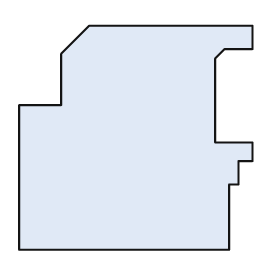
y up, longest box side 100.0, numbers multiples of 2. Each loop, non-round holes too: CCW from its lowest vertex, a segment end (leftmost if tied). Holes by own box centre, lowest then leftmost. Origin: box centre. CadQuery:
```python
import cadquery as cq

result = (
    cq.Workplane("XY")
    .moveTo(-50.0, -48.0)
    .lineTo(40.0, -48.0)
    .lineTo(40.0, -20.0)
    .lineTo(44.0, -20.0)
    .lineTo(44.0, -10.0)
    .lineTo(50.0, -10.0)
    .lineTo(50.0, -2.0)
    .lineTo(34.0, -2.0)
    .lineTo(34.0, 34.0)
    .lineTo(38.0, 38.0)
    .lineTo(50.0, 38.0)
    .lineTo(50.0, 48.0)
    .lineTo(-20.0, 48.0)
    .lineTo(-32.0, 36.0)
    .lineTo(-32.0, 14.0)
    .lineTo(-50.0, 14.0)
    .close()
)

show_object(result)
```